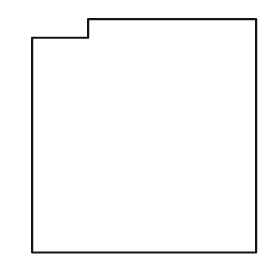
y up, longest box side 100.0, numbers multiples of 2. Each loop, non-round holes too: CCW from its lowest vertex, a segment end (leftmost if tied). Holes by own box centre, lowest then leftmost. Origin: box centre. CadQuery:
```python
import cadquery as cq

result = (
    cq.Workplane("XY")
    .moveTo(-48.0, -50.0)
    .lineTo(48.0, -50.0)
    .lineTo(48.0, 50.0)
    .lineTo(-24.0, 50.0)
    .lineTo(-24.0, 42.0)
    .lineTo(-48.0, 42.0)
    .close()
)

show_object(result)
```